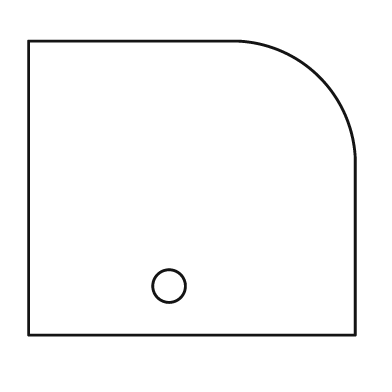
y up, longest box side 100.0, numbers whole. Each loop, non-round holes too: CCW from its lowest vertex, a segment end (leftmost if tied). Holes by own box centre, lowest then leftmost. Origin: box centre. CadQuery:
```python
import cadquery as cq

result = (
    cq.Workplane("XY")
    .moveTo(-50.0, -45.0)
    .lineTo(50.0, -45.0)
    .lineTo(50.0, 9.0)
    .threePointArc((39.0, 34.0), (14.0, 45.0))
    .lineTo(-50.0, 45.0)
    .close()
    .moveTo(-7.0, -30.0)
    .circle(5.0)
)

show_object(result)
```